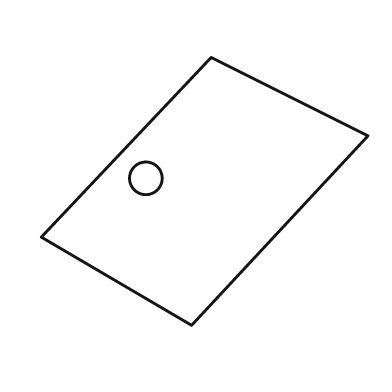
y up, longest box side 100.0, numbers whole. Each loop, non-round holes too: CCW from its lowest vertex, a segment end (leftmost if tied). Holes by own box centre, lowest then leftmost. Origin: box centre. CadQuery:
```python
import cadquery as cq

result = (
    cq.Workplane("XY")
    .moveTo(-4.0, -41.0)
    .lineTo(50.0, 17.0)
    .lineTo(2.0, 41.0)
    .lineTo(-50.0, -14.0)
    .close()
    .moveTo(-18.0, 4.0)
    .circle(5.0)
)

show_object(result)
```